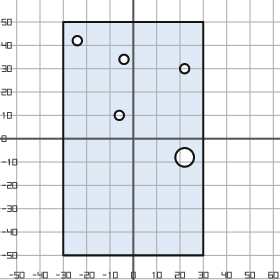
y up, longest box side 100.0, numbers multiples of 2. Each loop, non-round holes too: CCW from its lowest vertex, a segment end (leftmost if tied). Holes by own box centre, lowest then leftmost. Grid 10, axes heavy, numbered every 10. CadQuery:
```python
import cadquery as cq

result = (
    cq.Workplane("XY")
    .moveTo(-30.0, -50.0)
    .lineTo(30.0, -50.0)
    .lineTo(30.0, 50.0)
    .lineTo(-30.0, 50.0)
    .close()
    .moveTo(22.0, -8.0)
    .circle(4.0)
    .moveTo(-6.0, 10.0)
    .circle(2.0)
    .moveTo(22.0, 30.0)
    .circle(2.0)
    .moveTo(-4.0, 34.0)
    .circle(2.0)
    .moveTo(-24.0, 42.0)
    .circle(2.0)
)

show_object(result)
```